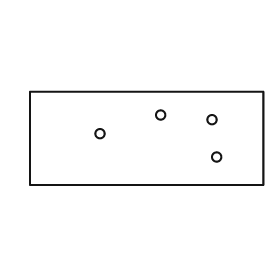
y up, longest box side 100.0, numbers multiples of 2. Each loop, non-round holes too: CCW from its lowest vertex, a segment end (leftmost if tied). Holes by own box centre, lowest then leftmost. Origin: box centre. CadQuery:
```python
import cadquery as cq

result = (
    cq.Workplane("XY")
    .moveTo(-50.0, -20.0)
    .lineTo(50.0, -20.0)
    .lineTo(50.0, 20.0)
    .lineTo(-50.0, 20.0)
    .close()
    .moveTo(30.0, -8.0)
    .circle(2.0)
    .moveTo(-20.0, 2.0)
    .circle(2.0)
    .moveTo(28.0, 8.0)
    .circle(2.0)
    .moveTo(6.0, 10.0)
    .circle(2.0)
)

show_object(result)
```